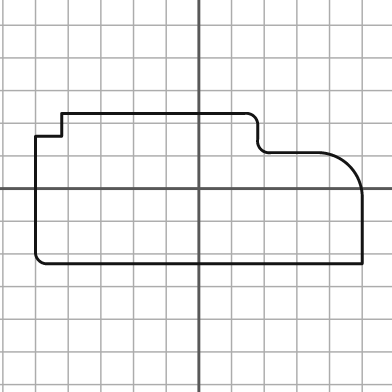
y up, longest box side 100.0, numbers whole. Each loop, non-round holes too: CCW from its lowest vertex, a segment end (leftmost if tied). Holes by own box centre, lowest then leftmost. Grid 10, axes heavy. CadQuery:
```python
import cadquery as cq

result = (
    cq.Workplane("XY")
    .moveTo(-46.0, -23.0)
    .lineTo(50.0, -23.0)
    .lineTo(50.0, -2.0)
    .threePointArc((46.0, 7.0), (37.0, 11.0))
    .lineTo(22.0, 11.0)
    .threePointArc((19.0, 12.0), (18.0, 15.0))
    .lineTo(18.0, 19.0)
    .threePointArc((17.0, 22.0), (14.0, 23.0))
    .lineTo(-42.0, 23.0)
    .lineTo(-42.0, 16.0)
    .lineTo(-50.0, 16.0)
    .lineTo(-50.0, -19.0)
    .threePointArc((-49.0, -22.0), (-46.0, -23.0))
    .close()
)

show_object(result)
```